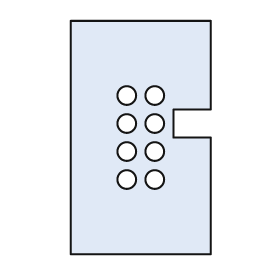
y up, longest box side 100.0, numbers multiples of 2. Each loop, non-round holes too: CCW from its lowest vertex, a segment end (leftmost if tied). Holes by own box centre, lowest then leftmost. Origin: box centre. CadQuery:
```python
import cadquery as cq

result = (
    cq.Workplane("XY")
    .moveTo(-30.0, -50.0)
    .lineTo(30.0, -50.0)
    .lineTo(30.0, 0.0)
    .lineTo(14.0, 0.0)
    .lineTo(14.0, 12.0)
    .lineTo(30.0, 12.0)
    .lineTo(30.0, 50.0)
    .lineTo(-30.0, 50.0)
    .close()
    .moveTo(-6.0, -18.0)
    .circle(4.0)
    .moveTo(6.0, -18.0)
    .circle(4.0)
    .moveTo(-6.0, -6.0)
    .circle(4.0)
    .moveTo(6.0, -6.0)
    .circle(4.0)
    .moveTo(-6.0, 6.0)
    .circle(4.0)
    .moveTo(6.0, 6.0)
    .circle(4.0)
    .moveTo(-6.0, 18.0)
    .circle(4.0)
    .moveTo(6.0, 18.0)
    .circle(4.0)
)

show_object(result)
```